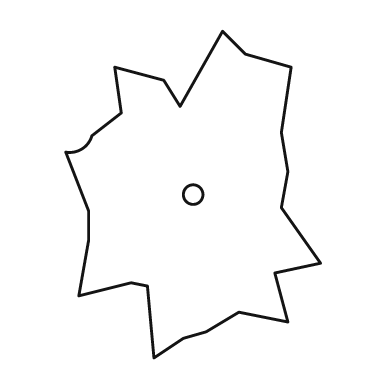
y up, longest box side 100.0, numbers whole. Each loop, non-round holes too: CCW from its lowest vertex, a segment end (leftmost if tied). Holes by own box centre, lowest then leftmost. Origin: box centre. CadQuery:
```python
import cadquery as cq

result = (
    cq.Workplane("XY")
    .moveTo(-12.0, -50.0)
    .lineTo(-3.0, -44.0)
    .lineTo(4.0, -42.0)
    .lineTo(14.0, -36.0)
    .lineTo(29.0, -39.0)
    .lineTo(25.0, -24.0)
    .lineTo(39.0, -21.0)
    .lineTo(27.0, -4.0)
    .lineTo(29.0, 7.0)
    .lineTo(27.0, 19.0)
    .lineTo(30.0, 39.0)
    .lineTo(16.0, 43.0)
    .lineTo(9.0, 50.0)
    .lineTo(-4.0, 27.0)
    .lineTo(-9.0, 35.0)
    .lineTo(-24.0, 39.0)
    .lineTo(-22.0, 25.0)
    .lineTo(-31.0, 18.0)
    .threePointArc((-34.0, 14.0), (-39.0, 13.0))
    .lineTo(-32.0, -5.0)
    .lineTo(-32.0, -14.0)
    .lineTo(-35.0, -31.0)
    .lineTo(-19.0, -27.0)
    .lineTo(-14.0, -28.0)
    .close()
    .moveTo(0.0, 0.0)
    .circle(3.0)
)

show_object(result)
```